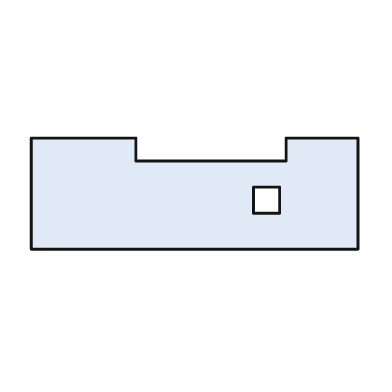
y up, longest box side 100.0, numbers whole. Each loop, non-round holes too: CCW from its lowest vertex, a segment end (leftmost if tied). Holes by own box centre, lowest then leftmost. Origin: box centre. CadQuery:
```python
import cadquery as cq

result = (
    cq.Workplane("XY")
    .moveTo(-50.0, -17.0)
    .lineTo(50.0, -17.0)
    .lineTo(50.0, 17.0)
    .lineTo(28.0, 17.0)
    .lineTo(28.0, 10.0)
    .lineTo(-18.0, 10.0)
    .lineTo(-18.0, 17.0)
    .lineTo(-50.0, 17.0)
    .close()
    .moveTo(18.0, -6.0)
    .lineTo(26.0, -6.0)
    .lineTo(26.0, 2.0)
    .lineTo(18.0, 2.0)
    .close()
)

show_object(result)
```